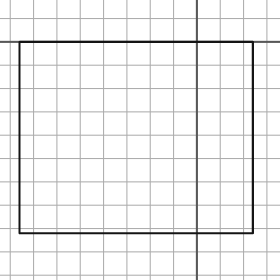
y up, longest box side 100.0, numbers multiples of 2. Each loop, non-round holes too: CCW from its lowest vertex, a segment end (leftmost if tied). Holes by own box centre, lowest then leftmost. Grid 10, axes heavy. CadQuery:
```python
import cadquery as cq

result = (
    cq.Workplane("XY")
    .moveTo(-76.0, -82.0)
    .lineTo(24.0, -82.0)
    .lineTo(24.0, 0.0)
    .lineTo(-76.0, 0.0)
    .close()
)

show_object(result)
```